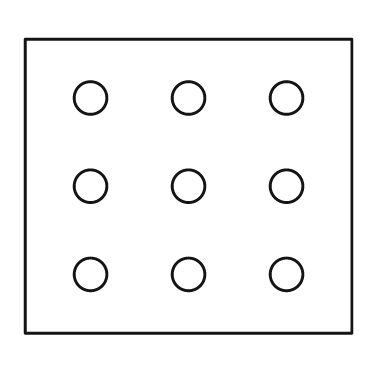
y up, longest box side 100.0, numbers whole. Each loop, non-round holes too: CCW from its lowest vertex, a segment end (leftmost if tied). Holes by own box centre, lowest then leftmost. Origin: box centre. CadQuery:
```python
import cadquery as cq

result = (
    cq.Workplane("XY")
    .moveTo(-50.0, -45.0)
    .lineTo(50.0, -45.0)
    .lineTo(50.0, 45.0)
    .lineTo(-50.0, 45.0)
    .close()
    .moveTo(-30.0, -27.0)
    .circle(5.0)
    .moveTo(0.0, -27.0)
    .circle(5.0)
    .moveTo(30.0, -27.0)
    .circle(5.0)
    .moveTo(-30.0, 0.0)
    .circle(5.0)
    .moveTo(0.0, 0.0)
    .circle(5.0)
    .moveTo(30.0, 0.0)
    .circle(5.0)
    .moveTo(-30.0, 27.0)
    .circle(5.0)
    .moveTo(0.0, 27.0)
    .circle(5.0)
    .moveTo(30.0, 27.0)
    .circle(5.0)
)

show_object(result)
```